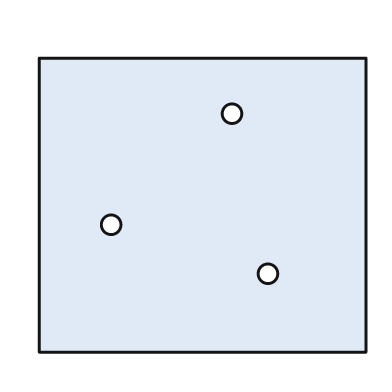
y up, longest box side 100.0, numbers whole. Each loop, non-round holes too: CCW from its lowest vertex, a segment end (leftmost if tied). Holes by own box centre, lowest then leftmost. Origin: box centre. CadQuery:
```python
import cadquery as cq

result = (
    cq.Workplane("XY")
    .moveTo(-50.0, -45.0)
    .lineTo(50.0, -45.0)
    .lineTo(50.0, 45.0)
    .lineTo(-50.0, 45.0)
    .close()
    .moveTo(20.0, -21.0)
    .circle(3.0)
    .moveTo(-28.0, -6.0)
    .circle(3.0)
    .moveTo(9.0, 28.0)
    .circle(3.0)
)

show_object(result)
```